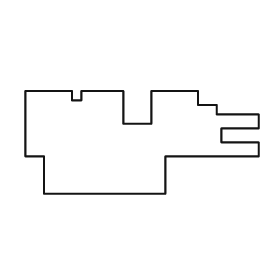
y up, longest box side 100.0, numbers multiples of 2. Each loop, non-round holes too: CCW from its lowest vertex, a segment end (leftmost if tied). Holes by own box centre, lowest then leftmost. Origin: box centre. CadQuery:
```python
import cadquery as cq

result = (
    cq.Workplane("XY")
    .moveTo(-42.0, -22.0)
    .lineTo(10.0, -22.0)
    .lineTo(10.0, -6.0)
    .lineTo(50.0, -6.0)
    .lineTo(50.0, 0.0)
    .lineTo(34.0, 0.0)
    .lineTo(34.0, 6.0)
    .lineTo(50.0, 6.0)
    .lineTo(50.0, 12.0)
    .lineTo(32.0, 12.0)
    .lineTo(32.0, 16.0)
    .lineTo(24.0, 16.0)
    .lineTo(24.0, 22.0)
    .lineTo(4.0, 22.0)
    .lineTo(4.0, 8.0)
    .lineTo(-8.0, 8.0)
    .lineTo(-8.0, 22.0)
    .lineTo(-26.0, 22.0)
    .lineTo(-26.0, 18.0)
    .lineTo(-30.0, 18.0)
    .lineTo(-30.0, 22.0)
    .lineTo(-50.0, 22.0)
    .lineTo(-50.0, -6.0)
    .lineTo(-42.0, -6.0)
    .close()
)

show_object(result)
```